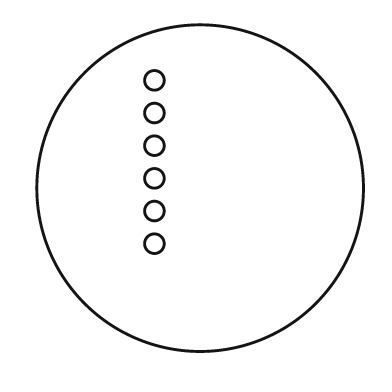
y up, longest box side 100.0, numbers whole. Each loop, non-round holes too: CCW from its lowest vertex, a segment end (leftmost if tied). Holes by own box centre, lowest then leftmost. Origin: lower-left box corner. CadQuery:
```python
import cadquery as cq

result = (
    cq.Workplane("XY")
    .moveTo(50.0, 50.0)
    .circle(50.0)
    .moveTo(36.0, 33.0)
    .circle(3.0)
    .moveTo(36.0, 43.0)
    .circle(3.0)
    .moveTo(36.0, 53.0)
    .circle(3.0)
    .moveTo(36.0, 63.0)
    .circle(3.0)
    .moveTo(36.0, 73.0)
    .circle(3.0)
    .moveTo(36.0, 83.0)
    .circle(3.0)
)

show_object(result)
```